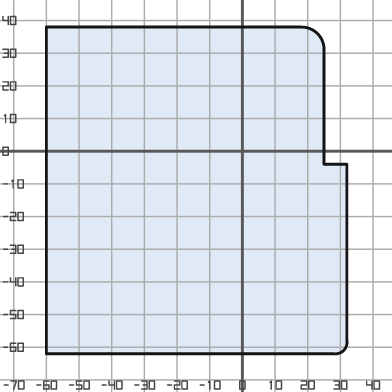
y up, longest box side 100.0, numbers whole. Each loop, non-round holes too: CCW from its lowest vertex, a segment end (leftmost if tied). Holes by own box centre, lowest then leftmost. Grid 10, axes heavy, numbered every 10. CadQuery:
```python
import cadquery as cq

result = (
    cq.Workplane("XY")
    .moveTo(-60.0, -62.0)
    .lineTo(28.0, -62.0)
    .threePointArc((31.0, -61.0), (32.0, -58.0))
    .lineTo(32.0, -4.0)
    .lineTo(25.0, -4.0)
    .lineTo(25.0, 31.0)
    .threePointArc((23.0, 36.0), (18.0, 38.0))
    .lineTo(-60.0, 38.0)
    .close()
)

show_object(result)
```